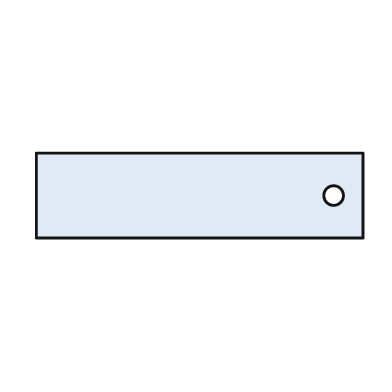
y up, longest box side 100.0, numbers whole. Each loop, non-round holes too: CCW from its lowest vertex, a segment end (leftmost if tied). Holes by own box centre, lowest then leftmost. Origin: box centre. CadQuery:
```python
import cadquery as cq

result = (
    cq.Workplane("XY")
    .moveTo(-50.0, -13.0)
    .lineTo(50.0, -13.0)
    .lineTo(50.0, 13.0)
    .lineTo(-50.0, 13.0)
    .close()
    .moveTo(41.0, 0.0)
    .circle(3.0)
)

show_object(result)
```